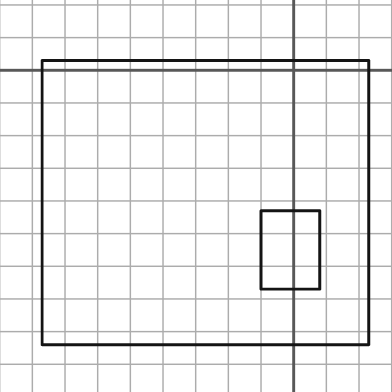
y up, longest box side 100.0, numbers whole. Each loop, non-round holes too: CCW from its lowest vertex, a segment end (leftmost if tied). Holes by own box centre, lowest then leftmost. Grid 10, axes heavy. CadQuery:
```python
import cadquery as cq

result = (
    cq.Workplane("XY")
    .moveTo(-77.0, -84.0)
    .lineTo(23.0, -84.0)
    .lineTo(23.0, 3.0)
    .lineTo(-77.0, 3.0)
    .close()
    .moveTo(-10.0, -67.0)
    .lineTo(8.0, -67.0)
    .lineTo(8.0, -43.0)
    .lineTo(-10.0, -43.0)
    .close()
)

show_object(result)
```